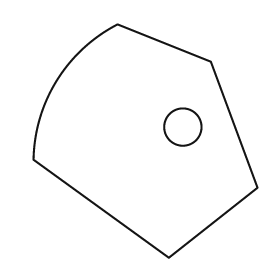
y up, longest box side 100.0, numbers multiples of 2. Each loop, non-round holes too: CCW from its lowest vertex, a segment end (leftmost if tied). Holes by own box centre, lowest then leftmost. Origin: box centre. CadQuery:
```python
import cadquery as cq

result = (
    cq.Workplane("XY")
    .moveTo(10.0, -50.0)
    .lineTo(48.0, -20.0)
    .lineTo(28.0, 34.0)
    .lineTo(-12.0, 50.0)
    .threePointArc((-38.0, 26.0), (-48.0, -8.0))
    .close()
    .moveTo(16.0, 6.0)
    .circle(8.0)
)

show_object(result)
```